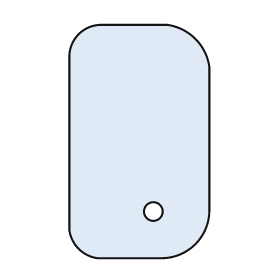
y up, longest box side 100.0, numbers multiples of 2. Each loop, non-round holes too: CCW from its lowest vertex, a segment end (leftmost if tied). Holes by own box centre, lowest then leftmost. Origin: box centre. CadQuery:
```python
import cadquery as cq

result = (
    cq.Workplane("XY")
    .moveTo(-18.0, -50.0)
    .lineTo(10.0, -50.0)
    .threePointArc((24.0, -44.0), (30.0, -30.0))
    .lineTo(30.0, 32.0)
    .threePointArc((24.0, 44.0), (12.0, 50.0))
    .lineTo(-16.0, 50.0)
    .threePointArc((-26.0, 46.0), (-30.0, 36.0))
    .lineTo(-30.0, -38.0)
    .threePointArc((-26.0, -46.0), (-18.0, -50.0))
    .close()
    .moveTo(6.0, -30.0)
    .circle(4.0)
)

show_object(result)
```